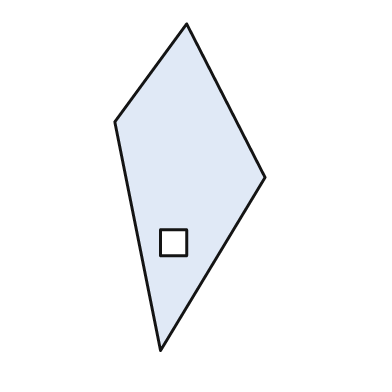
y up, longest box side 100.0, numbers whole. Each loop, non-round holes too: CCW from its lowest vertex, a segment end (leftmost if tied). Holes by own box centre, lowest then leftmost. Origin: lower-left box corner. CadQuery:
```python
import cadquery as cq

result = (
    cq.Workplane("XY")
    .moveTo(14.0, 0.0)
    .lineTo(46.0, 53.0)
    .lineTo(22.0, 100.0)
    .lineTo(0.0, 70.0)
    .close()
    .moveTo(14.0, 29.0)
    .lineTo(22.0, 29.0)
    .lineTo(22.0, 37.0)
    .lineTo(14.0, 37.0)
    .close()
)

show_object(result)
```